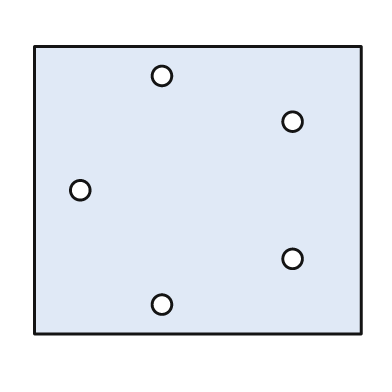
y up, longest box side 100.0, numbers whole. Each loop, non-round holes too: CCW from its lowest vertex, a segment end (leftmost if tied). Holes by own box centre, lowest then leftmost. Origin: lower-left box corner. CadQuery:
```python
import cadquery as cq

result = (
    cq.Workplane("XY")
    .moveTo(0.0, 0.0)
    .lineTo(100.0, 0.0)
    .lineTo(100.0, 88.0)
    .lineTo(0.0, 88.0)
    .close()
    .moveTo(39.0, 9.0)
    .circle(3.0)
    .moveTo(79.0, 23.0)
    .circle(3.0)
    .moveTo(14.0, 44.0)
    .circle(3.0)
    .moveTo(79.0, 65.0)
    .circle(3.0)
    .moveTo(39.0, 79.0)
    .circle(3.0)
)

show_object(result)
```